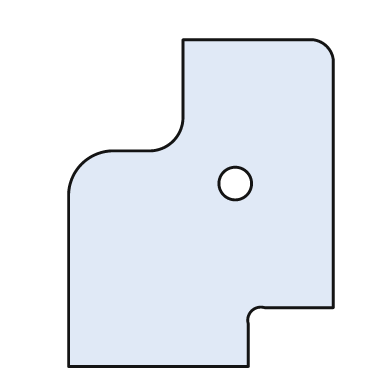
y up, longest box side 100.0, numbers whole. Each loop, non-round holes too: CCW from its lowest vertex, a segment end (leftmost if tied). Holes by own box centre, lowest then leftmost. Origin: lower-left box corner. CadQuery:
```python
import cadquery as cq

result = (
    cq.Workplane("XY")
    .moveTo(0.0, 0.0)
    .lineTo(55.0, 0.0)
    .lineTo(55.0, 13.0)
    .threePointArc((56.0, 17.0), (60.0, 18.0))
    .lineTo(81.0, 18.0)
    .lineTo(81.0, 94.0)
    .threePointArc((79.0, 98.0), (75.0, 100.0))
    .lineTo(35.0, 100.0)
    .lineTo(35.0, 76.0)
    .threePointArc((32.0, 69.0), (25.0, 66.0))
    .lineTo(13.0, 66.0)
    .threePointArc((4.0, 62.0), (0.0, 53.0))
    .close()
    .moveTo(51.0, 56.0)
    .circle(5.0)
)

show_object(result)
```